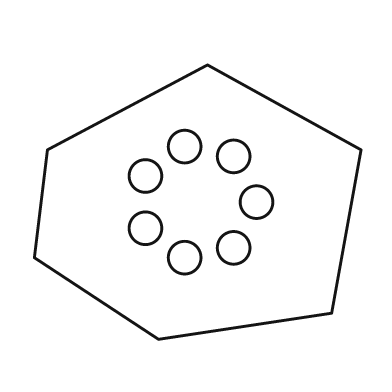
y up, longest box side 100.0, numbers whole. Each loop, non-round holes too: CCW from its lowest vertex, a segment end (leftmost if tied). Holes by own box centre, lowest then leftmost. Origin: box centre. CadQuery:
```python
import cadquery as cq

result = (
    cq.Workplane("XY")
    .moveTo(-12.0, -42.0)
    .lineTo(41.0, -34.0)
    .lineTo(50.0, 16.0)
    .lineTo(3.0, 42.0)
    .lineTo(-46.0, 16.0)
    .lineTo(-50.0, -17.0)
    .close()
    .moveTo(-4.0, -17.0)
    .circle(5.0)
    .moveTo(11.0, -14.0)
    .circle(5.0)
    .moveTo(-16.0, -8.0)
    .circle(5.0)
    .moveTo(18.0, 0.0)
    .circle(5.0)
    .moveTo(-16.0, 8.0)
    .circle(5.0)
    .moveTo(11.0, 14.0)
    .circle(5.0)
    .moveTo(-4.0, 17.0)
    .circle(5.0)
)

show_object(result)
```